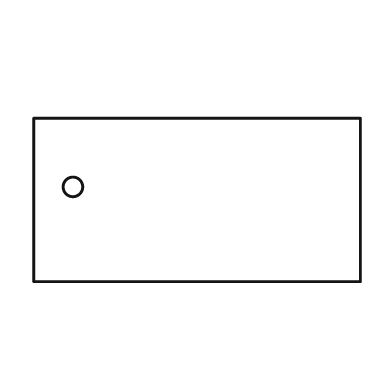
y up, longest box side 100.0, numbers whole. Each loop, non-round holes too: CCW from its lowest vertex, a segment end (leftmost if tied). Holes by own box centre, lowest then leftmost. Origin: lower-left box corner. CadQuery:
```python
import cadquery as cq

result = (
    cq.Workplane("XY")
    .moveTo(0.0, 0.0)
    .lineTo(100.0, 0.0)
    .lineTo(100.0, 50.0)
    .lineTo(0.0, 50.0)
    .close()
    .moveTo(12.0, 29.0)
    .circle(3.0)
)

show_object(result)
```